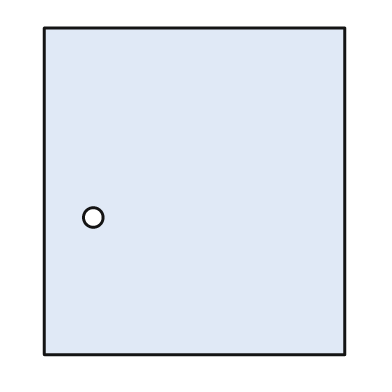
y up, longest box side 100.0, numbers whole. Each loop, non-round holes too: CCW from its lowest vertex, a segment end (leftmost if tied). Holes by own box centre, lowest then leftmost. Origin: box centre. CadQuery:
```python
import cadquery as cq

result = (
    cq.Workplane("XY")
    .moveTo(-46.0, -50.0)
    .lineTo(46.0, -50.0)
    .lineTo(46.0, 50.0)
    .lineTo(-46.0, 50.0)
    .close()
    .moveTo(-31.0, -8.0)
    .circle(3.0)
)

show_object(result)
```